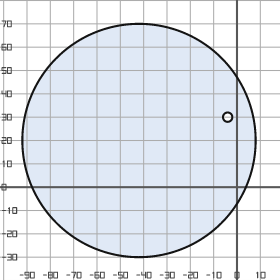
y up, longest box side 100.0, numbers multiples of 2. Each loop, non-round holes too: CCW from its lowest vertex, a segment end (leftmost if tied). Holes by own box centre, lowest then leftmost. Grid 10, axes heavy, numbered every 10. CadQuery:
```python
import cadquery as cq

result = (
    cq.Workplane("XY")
    .moveTo(-42.0, 20.0)
    .circle(50.0)
    .moveTo(-4.0, 30.0)
    .circle(2.0)
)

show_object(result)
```